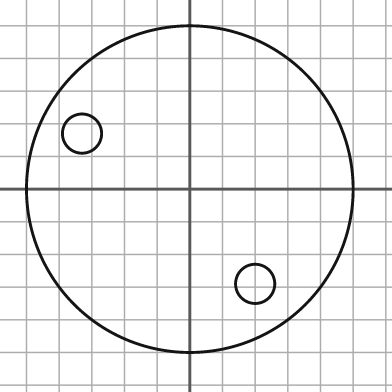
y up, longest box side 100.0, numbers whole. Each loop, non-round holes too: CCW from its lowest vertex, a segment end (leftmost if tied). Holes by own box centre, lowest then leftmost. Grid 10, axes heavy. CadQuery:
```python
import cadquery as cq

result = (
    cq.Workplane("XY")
    .moveTo(0.0, 0.0)
    .circle(50.0)
    .moveTo(20.0, -29.0)
    .circle(6.0)
    .moveTo(-33.0, 17.0)
    .circle(6.0)
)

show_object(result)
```